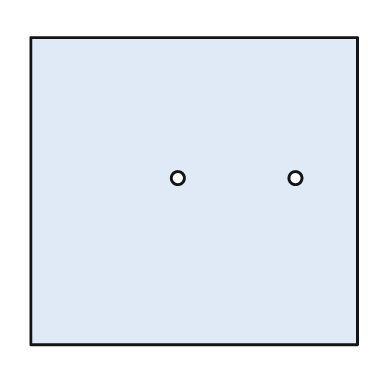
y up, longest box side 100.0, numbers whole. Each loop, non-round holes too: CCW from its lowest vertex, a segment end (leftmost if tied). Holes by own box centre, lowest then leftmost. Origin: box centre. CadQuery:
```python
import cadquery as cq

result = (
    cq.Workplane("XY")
    .moveTo(-50.0, -47.0)
    .lineTo(50.0, -47.0)
    .lineTo(50.0, 47.0)
    .lineTo(-50.0, 47.0)
    .close()
    .moveTo(-5.0, 4.0)
    .circle(2.0)
    .moveTo(31.0, 4.0)
    .circle(2.0)
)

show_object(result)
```